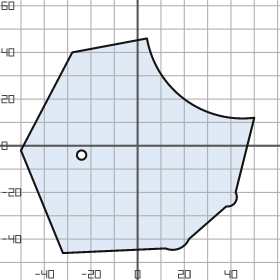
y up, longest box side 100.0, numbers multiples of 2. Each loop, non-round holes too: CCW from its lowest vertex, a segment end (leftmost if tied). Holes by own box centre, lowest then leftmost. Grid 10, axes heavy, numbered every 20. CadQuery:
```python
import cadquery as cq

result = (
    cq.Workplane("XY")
    .moveTo(-32.0, -46.0)
    .lineTo(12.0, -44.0)
    .threePointArc((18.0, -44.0), (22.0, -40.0))
    .lineTo(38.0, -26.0)
    .threePointArc((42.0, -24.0), (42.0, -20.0))
    .lineTo(50.0, 12.0)
    .threePointArc((20.0, 20.0), (4.0, 46.0))
    .lineTo(-28.0, 40.0)
    .lineTo(-50.0, -2.0)
    .close()
    .moveTo(-24.0, -4.0)
    .circle(2.0)
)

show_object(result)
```